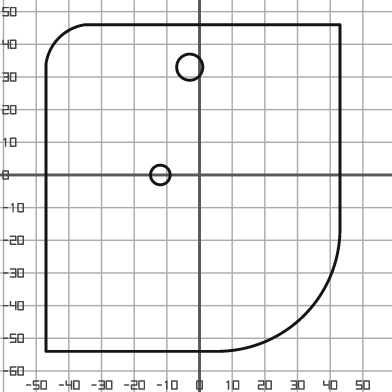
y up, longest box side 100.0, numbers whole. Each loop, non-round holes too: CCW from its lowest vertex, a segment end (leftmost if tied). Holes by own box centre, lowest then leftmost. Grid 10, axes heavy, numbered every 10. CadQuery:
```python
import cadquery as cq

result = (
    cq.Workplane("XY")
    .moveTo(-47.0, -54.0)
    .lineTo(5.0, -54.0)
    .threePointArc((32.0, -43.0), (43.0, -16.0))
    .lineTo(43.0, 46.0)
    .lineTo(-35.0, 46.0)
    .threePointArc((-43.0, 42.0), (-47.0, 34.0))
    .close()
    .moveTo(-12.0, 0.0)
    .circle(3.0)
    .moveTo(-3.0, 33.0)
    .circle(4.0)
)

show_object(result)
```